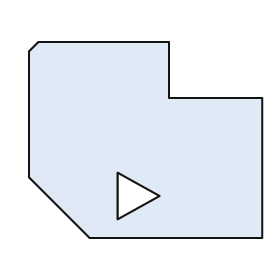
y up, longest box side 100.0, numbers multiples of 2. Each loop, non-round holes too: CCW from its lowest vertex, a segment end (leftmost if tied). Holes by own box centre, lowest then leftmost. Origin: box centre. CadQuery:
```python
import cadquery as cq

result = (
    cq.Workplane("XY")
    .moveTo(-24.0, -42.0)
    .lineTo(50.0, -42.0)
    .lineTo(50.0, 18.0)
    .lineTo(10.0, 18.0)
    .lineTo(10.0, 42.0)
    .lineTo(-46.0, 42.0)
    .lineTo(-50.0, 38.0)
    .lineTo(-50.0, -16.0)
    .close()
    .moveTo(-12.0, -34.0)
    .lineTo(6.0, -24.0)
    .lineTo(-12.0, -14.0)
    .close()
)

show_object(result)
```